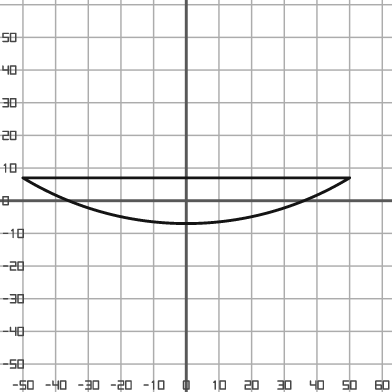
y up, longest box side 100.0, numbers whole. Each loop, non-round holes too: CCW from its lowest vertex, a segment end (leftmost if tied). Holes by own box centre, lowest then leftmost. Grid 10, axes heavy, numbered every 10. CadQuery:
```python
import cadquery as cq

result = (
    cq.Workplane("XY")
    .moveTo(-50.0, 7.0)
    .threePointArc((0.0, -7.0), (50.0, 7.0))
    .close()
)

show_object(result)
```